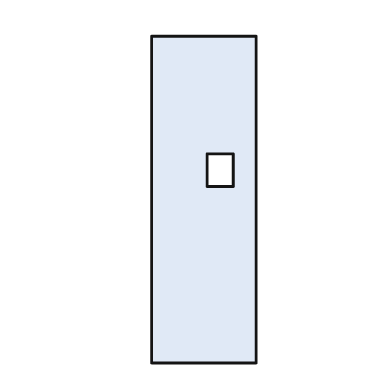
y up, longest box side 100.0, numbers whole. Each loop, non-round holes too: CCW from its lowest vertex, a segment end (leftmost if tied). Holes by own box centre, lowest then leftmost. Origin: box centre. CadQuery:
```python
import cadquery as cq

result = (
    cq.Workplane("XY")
    .moveTo(-16.0, -50.0)
    .lineTo(16.0, -50.0)
    .lineTo(16.0, 50.0)
    .lineTo(-16.0, 50.0)
    .close()
    .moveTo(1.0, 4.0)
    .lineTo(9.0, 4.0)
    .lineTo(9.0, 14.0)
    .lineTo(1.0, 14.0)
    .close()
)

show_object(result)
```